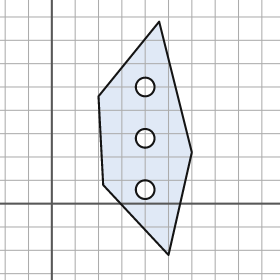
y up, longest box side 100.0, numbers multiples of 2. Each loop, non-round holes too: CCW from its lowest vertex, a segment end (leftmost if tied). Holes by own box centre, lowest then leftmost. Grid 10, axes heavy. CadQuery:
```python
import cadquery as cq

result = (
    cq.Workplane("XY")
    .moveTo(50.0, -22.0)
    .lineTo(60.0, 22.0)
    .lineTo(46.0, 78.0)
    .lineTo(20.0, 46.0)
    .lineTo(22.0, 8.0)
    .close()
    .moveTo(40.0, 6.0)
    .circle(4.0)
    .moveTo(40.0, 28.0)
    .circle(4.0)
    .moveTo(40.0, 50.0)
    .circle(4.0)
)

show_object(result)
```